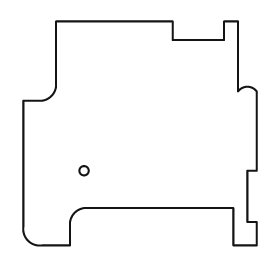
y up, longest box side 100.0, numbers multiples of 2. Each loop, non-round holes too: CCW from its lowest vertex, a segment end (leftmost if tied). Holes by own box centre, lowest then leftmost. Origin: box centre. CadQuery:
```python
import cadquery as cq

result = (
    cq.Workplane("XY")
    .moveTo(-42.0, -48.0)
    .lineTo(-30.0, -48.0)
    .lineTo(-30.0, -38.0)
    .threePointArc((-28.0, -34.0), (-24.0, -32.0))
    .lineTo(40.0, -32.0)
    .lineTo(40.0, -48.0)
    .lineTo(50.0, -48.0)
    .lineTo(50.0, -38.0)
    .lineTo(46.0, -38.0)
    .lineTo(46.0, -16.0)
    .lineTo(50.0, -16.0)
    .lineTo(50.0, 18.0)
    .threePointArc((46.0, 20.0), (42.0, 18.0))
    .lineTo(42.0, 48.0)
    .lineTo(36.0, 48.0)
    .lineTo(36.0, 40.0)
    .lineTo(14.0, 40.0)
    .lineTo(14.0, 48.0)
    .lineTo(-36.0, 48.0)
    .lineTo(-36.0, 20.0)
    .threePointArc((-38.0, 16.0), (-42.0, 14.0))
    .lineTo(-50.0, 14.0)
    .lineTo(-50.0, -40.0)
    .threePointArc((-48.0, -46.0), (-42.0, -48.0))
    .close()
    .moveTo(-24.0, -16.0)
    .circle(2.0)
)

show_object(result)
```